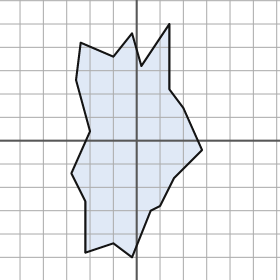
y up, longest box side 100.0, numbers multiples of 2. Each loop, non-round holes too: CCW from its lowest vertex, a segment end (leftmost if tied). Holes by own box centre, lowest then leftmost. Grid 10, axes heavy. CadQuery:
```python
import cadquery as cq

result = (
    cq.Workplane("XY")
    .moveTo(-2.0, -50.0)
    .lineTo(6.0, -30.0)
    .lineTo(10.0, -28.0)
    .lineTo(16.0, -16.0)
    .lineTo(28.0, -4.0)
    .lineTo(20.0, 14.0)
    .lineTo(14.0, 22.0)
    .lineTo(14.0, 50.0)
    .lineTo(2.0, 32.0)
    .lineTo(-2.0, 46.0)
    .lineTo(-10.0, 36.0)
    .lineTo(-24.0, 42.0)
    .lineTo(-26.0, 26.0)
    .lineTo(-20.0, 4.0)
    .lineTo(-28.0, -14.0)
    .lineTo(-22.0, -26.0)
    .lineTo(-22.0, -48.0)
    .lineTo(-10.0, -44.0)
    .close()
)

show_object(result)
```